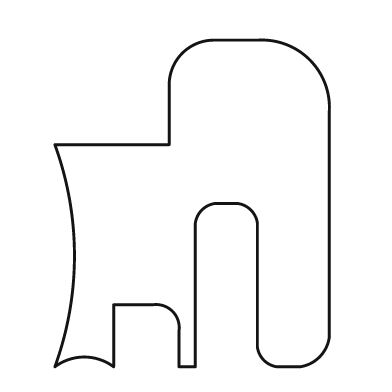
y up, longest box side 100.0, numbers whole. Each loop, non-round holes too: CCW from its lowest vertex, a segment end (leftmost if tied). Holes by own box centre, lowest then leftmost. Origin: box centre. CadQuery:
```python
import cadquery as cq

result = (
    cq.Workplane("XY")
    .moveTo(-42.0, -50.0)
    .threePointArc((-33.0, -47.0), (-24.0, -50.0))
    .lineTo(-24.0, -31.0)
    .lineTo(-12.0, -31.0)
    .threePointArc((-6.0, -33.0), (-4.0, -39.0))
    .lineTo(-4.0, -50.0)
    .lineTo(1.0, -50.0)
    .lineTo(1.0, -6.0)
    .threePointArc((3.0, -2.0), (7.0, 0.0))
    .lineTo(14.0, 0.0)
    .threePointArc((18.0, -2.0), (20.0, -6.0))
    .lineTo(20.0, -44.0)
    .threePointArc((22.0, -48.0), (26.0, -50.0))
    .lineTo(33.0, -50.0)
    .threePointArc((39.0, -47.0), (42.0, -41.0))
    .lineTo(42.0, 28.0)
    .threePointArc((36.0, 44.0), (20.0, 50.0))
    .lineTo(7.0, 50.0)
    .threePointArc((-3.0, 46.0), (-7.0, 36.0))
    .lineTo(-7.0, 18.0)
    .lineTo(-42.0, 18.0)
    .threePointArc((-36.0, -16.0), (-42.0, -50.0))
    .close()
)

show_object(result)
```